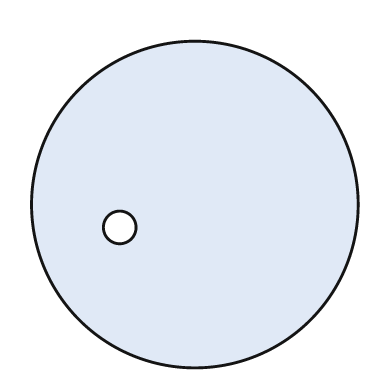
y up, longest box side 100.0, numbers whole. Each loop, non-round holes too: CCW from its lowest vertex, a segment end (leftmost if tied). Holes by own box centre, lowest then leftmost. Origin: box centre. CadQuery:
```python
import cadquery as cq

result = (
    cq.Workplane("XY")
    .moveTo(0.0, 0.0)
    .circle(50.0)
    .moveTo(-23.0, -7.0)
    .circle(5.0)
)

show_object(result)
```